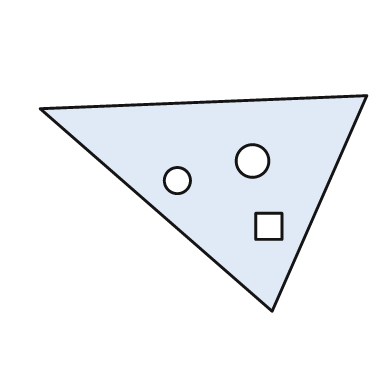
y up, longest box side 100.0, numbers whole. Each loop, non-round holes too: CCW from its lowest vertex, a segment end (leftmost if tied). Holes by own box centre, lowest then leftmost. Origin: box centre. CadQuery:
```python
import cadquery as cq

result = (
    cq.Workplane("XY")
    .moveTo(21.0, -33.0)
    .lineTo(50.0, 33.0)
    .lineTo(-50.0, 29.0)
    .close()
    .moveTo(16.0, -11.0)
    .lineTo(24.0, -11.0)
    .lineTo(24.0, -3.0)
    .lineTo(16.0, -3.0)
    .close()
    .moveTo(-8.0, 7.0)
    .circle(4.0)
    .moveTo(15.0, 13.0)
    .circle(5.0)
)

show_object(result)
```